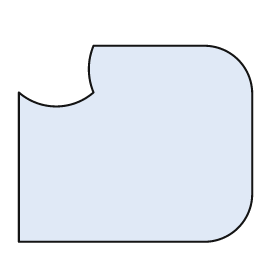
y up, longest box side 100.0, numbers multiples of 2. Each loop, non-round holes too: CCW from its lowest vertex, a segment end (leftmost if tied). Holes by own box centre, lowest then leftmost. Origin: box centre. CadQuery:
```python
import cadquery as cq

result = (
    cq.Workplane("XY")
    .moveTo(-50.0, -42.0)
    .lineTo(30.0, -42.0)
    .threePointArc((44.0, -36.0), (50.0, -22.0))
    .lineTo(50.0, 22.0)
    .threePointArc((44.0, 36.0), (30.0, 42.0))
    .lineTo(-18.0, 42.0)
    .threePointArc((-20.0, 32.0), (-18.0, 22.0))
    .threePointArc((-34.0, 16.0), (-50.0, 22.0))
    .close()
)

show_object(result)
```